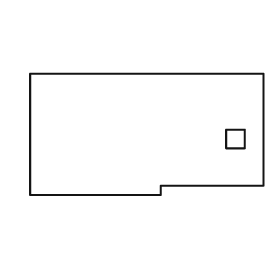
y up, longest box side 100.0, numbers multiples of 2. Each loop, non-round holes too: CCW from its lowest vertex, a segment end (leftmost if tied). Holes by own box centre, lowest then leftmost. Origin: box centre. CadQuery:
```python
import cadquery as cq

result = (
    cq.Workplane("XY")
    .moveTo(-50.0, -26.0)
    .lineTo(6.0, -26.0)
    .lineTo(6.0, -22.0)
    .lineTo(50.0, -22.0)
    .lineTo(50.0, 26.0)
    .lineTo(-50.0, 26.0)
    .close()
    .moveTo(34.0, -6.0)
    .lineTo(42.0, -6.0)
    .lineTo(42.0, 2.0)
    .lineTo(34.0, 2.0)
    .close()
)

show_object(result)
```